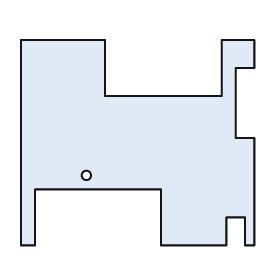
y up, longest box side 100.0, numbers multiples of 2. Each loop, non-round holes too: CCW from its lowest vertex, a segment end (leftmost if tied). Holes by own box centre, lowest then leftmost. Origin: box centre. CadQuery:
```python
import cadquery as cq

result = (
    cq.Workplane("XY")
    .moveTo(-50.0, -44.0)
    .lineTo(-44.0, -44.0)
    .lineTo(-44.0, -20.0)
    .lineTo(10.0, -20.0)
    .lineTo(10.0, -44.0)
    .lineTo(38.0, -44.0)
    .lineTo(38.0, -32.0)
    .lineTo(46.0, -32.0)
    .lineTo(46.0, -44.0)
    .lineTo(50.0, -44.0)
    .lineTo(50.0, 2.0)
    .lineTo(42.0, 2.0)
    .lineTo(42.0, 32.0)
    .lineTo(50.0, 32.0)
    .lineTo(50.0, 44.0)
    .lineTo(36.0, 44.0)
    .lineTo(36.0, 20.0)
    .lineTo(-14.0, 20.0)
    .lineTo(-14.0, 44.0)
    .lineTo(-50.0, 44.0)
    .close()
    .moveTo(-22.0, -14.0)
    .circle(2.0)
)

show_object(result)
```